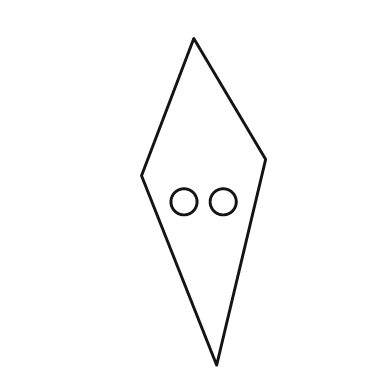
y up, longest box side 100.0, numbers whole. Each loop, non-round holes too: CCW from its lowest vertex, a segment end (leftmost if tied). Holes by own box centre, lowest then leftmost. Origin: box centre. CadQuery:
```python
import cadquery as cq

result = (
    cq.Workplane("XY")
    .moveTo(4.0, -50.0)
    .lineTo(19.0, 13.0)
    .lineTo(-3.0, 50.0)
    .lineTo(-19.0, 8.0)
    .close()
    .moveTo(-6.0, 0.0)
    .circle(4.0)
    .moveTo(6.0, 0.0)
    .circle(4.0)
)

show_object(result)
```